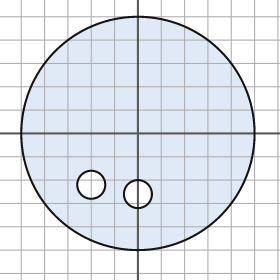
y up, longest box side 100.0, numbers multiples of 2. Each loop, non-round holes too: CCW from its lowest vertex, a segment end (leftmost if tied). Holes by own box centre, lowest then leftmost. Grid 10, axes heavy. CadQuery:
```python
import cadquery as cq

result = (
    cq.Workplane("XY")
    .moveTo(0.0, 0.0)
    .circle(50.0)
    .moveTo(0.0, -26.0)
    .circle(6.0)
    .moveTo(-20.0, -22.0)
    .circle(6.0)
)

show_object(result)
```